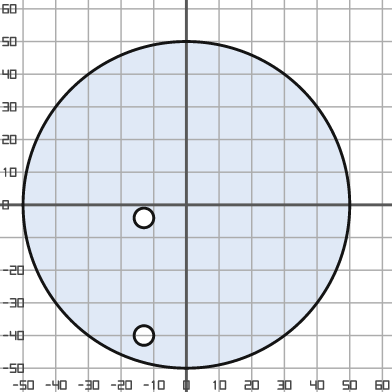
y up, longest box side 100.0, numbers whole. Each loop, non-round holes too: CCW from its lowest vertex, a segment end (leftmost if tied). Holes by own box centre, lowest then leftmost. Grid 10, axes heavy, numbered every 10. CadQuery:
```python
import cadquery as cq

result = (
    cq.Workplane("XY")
    .moveTo(0.0, 0.0)
    .circle(50.0)
    .moveTo(-13.0, -40.0)
    .circle(3.0)
    .moveTo(-13.0, -4.0)
    .circle(3.0)
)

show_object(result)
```